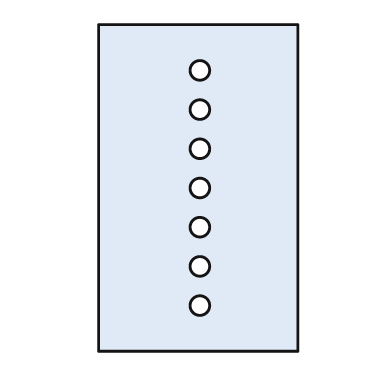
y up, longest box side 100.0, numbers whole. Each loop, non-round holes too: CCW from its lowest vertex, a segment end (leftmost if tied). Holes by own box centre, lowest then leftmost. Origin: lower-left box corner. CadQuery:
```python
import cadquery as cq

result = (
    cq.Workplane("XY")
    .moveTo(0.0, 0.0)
    .lineTo(61.0, 0.0)
    .lineTo(61.0, 100.0)
    .lineTo(0.0, 100.0)
    .close()
    .moveTo(31.0, 14.0)
    .circle(3.0)
    .moveTo(31.0, 26.0)
    .circle(3.0)
    .moveTo(31.0, 38.0)
    .circle(3.0)
    .moveTo(31.0, 50.0)
    .circle(3.0)
    .moveTo(31.0, 62.0)
    .circle(3.0)
    .moveTo(31.0, 74.0)
    .circle(3.0)
    .moveTo(31.0, 86.0)
    .circle(3.0)
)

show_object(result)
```